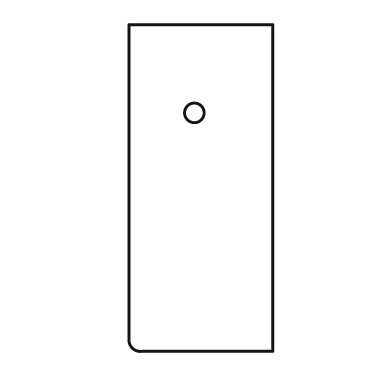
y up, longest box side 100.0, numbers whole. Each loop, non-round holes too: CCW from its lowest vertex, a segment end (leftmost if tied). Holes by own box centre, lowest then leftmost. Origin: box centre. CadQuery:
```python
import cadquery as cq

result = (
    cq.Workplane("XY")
    .moveTo(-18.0, -50.0)
    .lineTo(22.0, -50.0)
    .lineTo(22.0, 50.0)
    .lineTo(-22.0, 50.0)
    .lineTo(-22.0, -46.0)
    .threePointArc((-21.0, -49.0), (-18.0, -50.0))
    .close()
    .moveTo(-2.0, 23.0)
    .circle(3.0)
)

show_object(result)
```